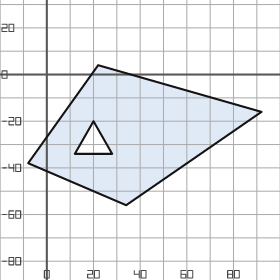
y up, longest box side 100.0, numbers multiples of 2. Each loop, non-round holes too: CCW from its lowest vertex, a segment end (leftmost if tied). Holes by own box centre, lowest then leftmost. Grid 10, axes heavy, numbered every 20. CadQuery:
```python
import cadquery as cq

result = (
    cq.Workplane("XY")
    .moveTo(34.0, -56.0)
    .lineTo(92.0, -16.0)
    .lineTo(22.0, 4.0)
    .lineTo(-8.0, -38.0)
    .close()
    .moveTo(12.0, -34.0)
    .lineTo(28.0, -34.0)
    .lineTo(20.0, -20.0)
    .close()
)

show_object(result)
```